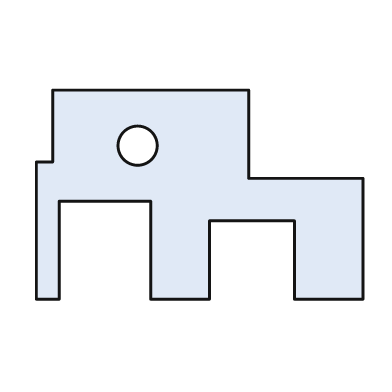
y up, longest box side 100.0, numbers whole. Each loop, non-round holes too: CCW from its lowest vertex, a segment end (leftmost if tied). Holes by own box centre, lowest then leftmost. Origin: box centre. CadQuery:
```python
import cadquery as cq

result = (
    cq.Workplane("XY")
    .moveTo(-50.0, -32.0)
    .lineTo(-43.0, -32.0)
    .lineTo(-43.0, -2.0)
    .lineTo(-15.0, -2.0)
    .lineTo(-15.0, -32.0)
    .lineTo(3.0, -32.0)
    .lineTo(3.0, -8.0)
    .lineTo(29.0, -8.0)
    .lineTo(29.0, -32.0)
    .lineTo(50.0, -32.0)
    .lineTo(50.0, 5.0)
    .lineTo(15.0, 5.0)
    .lineTo(15.0, 32.0)
    .lineTo(-45.0, 32.0)
    .lineTo(-45.0, 10.0)
    .lineTo(-50.0, 10.0)
    .close()
    .moveTo(-19.0, 15.0)
    .circle(6.0)
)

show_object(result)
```